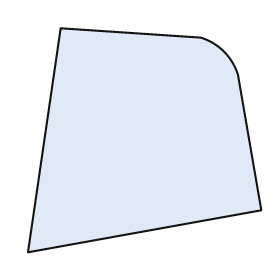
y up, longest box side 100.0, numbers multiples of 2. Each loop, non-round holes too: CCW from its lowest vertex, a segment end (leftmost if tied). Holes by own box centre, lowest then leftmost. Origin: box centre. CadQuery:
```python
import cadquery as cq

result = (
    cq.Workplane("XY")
    .moveTo(-50.0, -48.0)
    .lineTo(50.0, -30.0)
    .lineTo(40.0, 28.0)
    .threePointArc((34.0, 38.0), (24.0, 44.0))
    .lineTo(-36.0, 48.0)
    .close()
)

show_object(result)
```